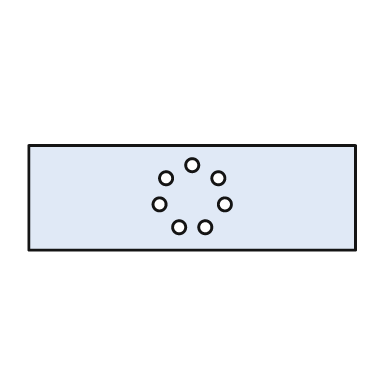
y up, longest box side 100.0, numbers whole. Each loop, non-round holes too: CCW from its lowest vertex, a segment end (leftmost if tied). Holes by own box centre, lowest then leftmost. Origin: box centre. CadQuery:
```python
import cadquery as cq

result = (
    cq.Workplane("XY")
    .moveTo(-50.0, -16.0)
    .lineTo(50.0, -16.0)
    .lineTo(50.0, 16.0)
    .lineTo(-50.0, 16.0)
    .close()
    .moveTo(-4.0, -9.0)
    .circle(2.0)
    .moveTo(4.0, -9.0)
    .circle(2.0)
    .moveTo(-10.0, -2.0)
    .circle(2.0)
    .moveTo(10.0, -2.0)
    .circle(2.0)
    .moveTo(-8.0, 6.0)
    .circle(2.0)
    .moveTo(8.0, 6.0)
    .circle(2.0)
    .moveTo(0.0, 10.0)
    .circle(2.0)
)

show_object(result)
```